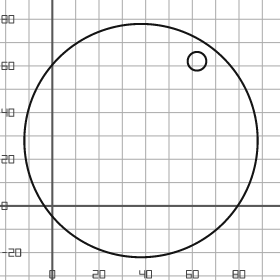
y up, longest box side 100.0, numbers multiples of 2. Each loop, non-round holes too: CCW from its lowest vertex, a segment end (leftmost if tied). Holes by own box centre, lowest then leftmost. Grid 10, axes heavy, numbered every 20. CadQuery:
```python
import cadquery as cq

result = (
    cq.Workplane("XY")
    .moveTo(38.0, 28.0)
    .circle(50.0)
    .moveTo(62.0, 62.0)
    .circle(4.0)
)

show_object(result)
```